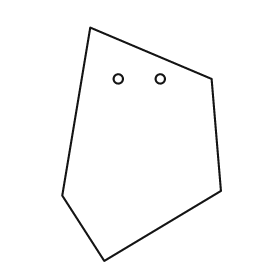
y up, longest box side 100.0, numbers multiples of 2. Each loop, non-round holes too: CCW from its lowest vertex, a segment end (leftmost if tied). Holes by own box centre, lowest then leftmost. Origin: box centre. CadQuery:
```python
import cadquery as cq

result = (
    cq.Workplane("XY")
    .moveTo(-16.0, -50.0)
    .lineTo(34.0, -20.0)
    .lineTo(30.0, 28.0)
    .lineTo(-22.0, 50.0)
    .lineTo(-34.0, -22.0)
    .close()
    .moveTo(-10.0, 28.0)
    .circle(2.0)
    .moveTo(8.0, 28.0)
    .circle(2.0)
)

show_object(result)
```